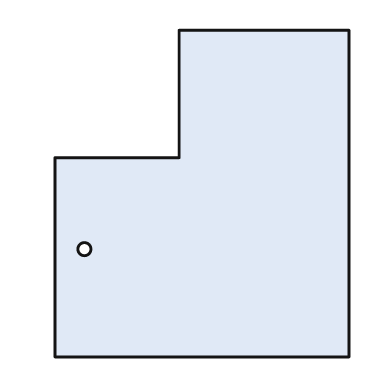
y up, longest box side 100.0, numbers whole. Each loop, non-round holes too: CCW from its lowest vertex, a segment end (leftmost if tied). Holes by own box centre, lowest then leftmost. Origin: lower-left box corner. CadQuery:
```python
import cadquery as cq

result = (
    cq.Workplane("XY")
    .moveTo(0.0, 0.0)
    .lineTo(90.0, 0.0)
    .lineTo(90.0, 100.0)
    .lineTo(38.0, 100.0)
    .lineTo(38.0, 61.0)
    .lineTo(0.0, 61.0)
    .close()
    .moveTo(9.0, 33.0)
    .circle(2.0)
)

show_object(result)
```